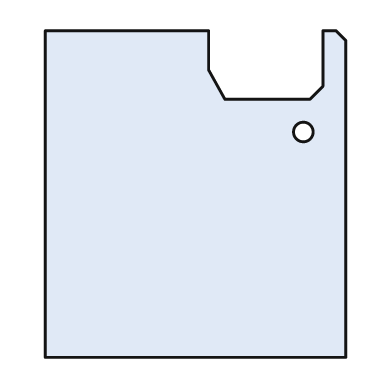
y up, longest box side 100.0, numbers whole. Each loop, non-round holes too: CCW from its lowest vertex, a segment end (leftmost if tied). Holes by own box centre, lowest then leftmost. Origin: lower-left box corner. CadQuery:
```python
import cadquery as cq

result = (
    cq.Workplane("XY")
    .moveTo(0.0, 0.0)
    .lineTo(92.0, 0.0)
    .lineTo(92.0, 97.0)
    .lineTo(89.0, 100.0)
    .lineTo(85.0, 100.0)
    .lineTo(85.0, 83.0)
    .lineTo(81.0, 79.0)
    .lineTo(55.0, 79.0)
    .lineTo(50.0, 88.0)
    .lineTo(50.0, 100.0)
    .lineTo(0.0, 100.0)
    .close()
    .moveTo(79.0, 69.0)
    .circle(3.0)
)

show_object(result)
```